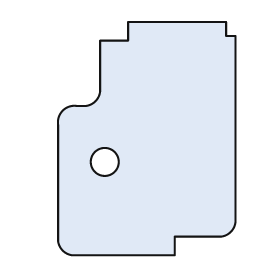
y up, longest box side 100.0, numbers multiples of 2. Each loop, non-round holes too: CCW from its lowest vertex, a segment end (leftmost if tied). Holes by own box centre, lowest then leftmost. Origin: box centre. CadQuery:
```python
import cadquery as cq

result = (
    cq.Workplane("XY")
    .moveTo(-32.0, -50.0)
    .lineTo(12.0, -50.0)
    .lineTo(12.0, -42.0)
    .lineTo(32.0, -42.0)
    .threePointArc((36.0, -40.0), (38.0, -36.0))
    .lineTo(38.0, 44.0)
    .lineTo(34.0, 44.0)
    .lineTo(34.0, 50.0)
    .lineTo(-8.0, 50.0)
    .lineTo(-8.0, 42.0)
    .lineTo(-20.0, 42.0)
    .lineTo(-20.0, 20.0)
    .threePointArc((-22.0, 16.0), (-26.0, 14.0))
    .lineTo(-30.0, 14.0)
    .threePointArc((-36.0, 12.0), (-38.0, 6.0))
    .lineTo(-38.0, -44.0)
    .threePointArc((-36.0, -48.0), (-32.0, -50.0))
    .close()
    .moveTo(-18.0, -10.0)
    .circle(6.0)
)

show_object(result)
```